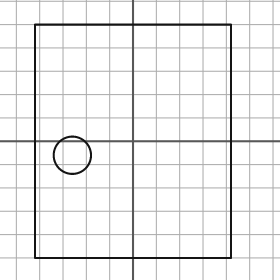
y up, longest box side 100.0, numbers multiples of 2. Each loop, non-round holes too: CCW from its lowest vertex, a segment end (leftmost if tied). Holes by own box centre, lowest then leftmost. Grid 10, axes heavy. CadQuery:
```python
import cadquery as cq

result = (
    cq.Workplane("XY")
    .moveTo(-42.0, -50.0)
    .lineTo(42.0, -50.0)
    .lineTo(42.0, 50.0)
    .lineTo(-42.0, 50.0)
    .close()
    .moveTo(-26.0, -6.0)
    .circle(8.0)
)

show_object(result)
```